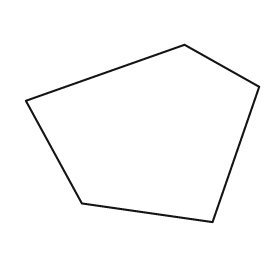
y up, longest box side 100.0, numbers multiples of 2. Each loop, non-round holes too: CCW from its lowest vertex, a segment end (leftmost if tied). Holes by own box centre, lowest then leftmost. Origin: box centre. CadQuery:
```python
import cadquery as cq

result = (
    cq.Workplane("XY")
    .moveTo(30.0, -38.0)
    .lineTo(50.0, 20.0)
    .lineTo(18.0, 38.0)
    .lineTo(-50.0, 14.0)
    .lineTo(-26.0, -30.0)
    .close()
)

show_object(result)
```